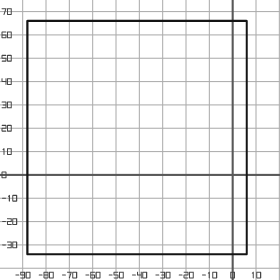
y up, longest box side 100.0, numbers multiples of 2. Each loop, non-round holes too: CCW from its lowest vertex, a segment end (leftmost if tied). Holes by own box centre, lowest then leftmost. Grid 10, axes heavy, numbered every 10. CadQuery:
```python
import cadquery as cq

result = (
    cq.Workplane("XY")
    .moveTo(-88.0, -34.0)
    .lineTo(6.0, -34.0)
    .lineTo(6.0, 66.0)
    .lineTo(-88.0, 66.0)
    .close()
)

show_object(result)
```